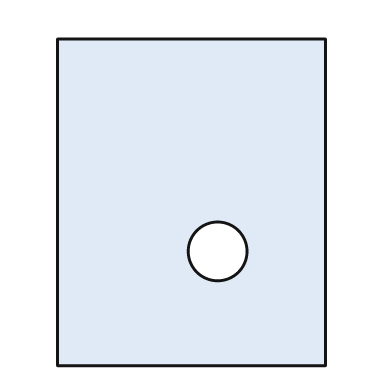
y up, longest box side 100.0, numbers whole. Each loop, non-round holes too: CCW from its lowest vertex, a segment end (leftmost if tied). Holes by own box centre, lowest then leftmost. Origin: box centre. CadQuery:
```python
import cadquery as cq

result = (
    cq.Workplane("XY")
    .moveTo(-41.0, -50.0)
    .lineTo(41.0, -50.0)
    .lineTo(41.0, 50.0)
    .lineTo(-41.0, 50.0)
    .close()
    .moveTo(8.0, -15.0)
    .circle(9.0)
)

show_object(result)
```